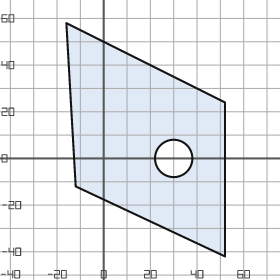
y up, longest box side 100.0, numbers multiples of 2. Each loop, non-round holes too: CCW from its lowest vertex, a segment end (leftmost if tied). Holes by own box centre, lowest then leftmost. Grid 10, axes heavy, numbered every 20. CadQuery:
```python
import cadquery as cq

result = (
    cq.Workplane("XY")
    .moveTo(52.0, -42.0)
    .lineTo(52.0, 24.0)
    .lineTo(-16.0, 58.0)
    .lineTo(-12.0, -12.0)
    .close()
    .moveTo(30.0, 0.0)
    .circle(8.0)
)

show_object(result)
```